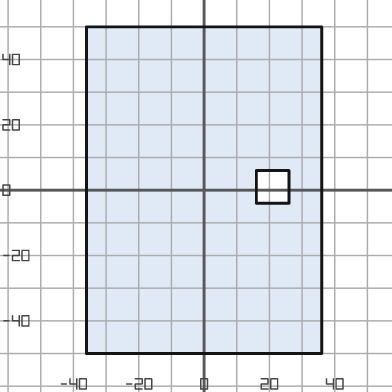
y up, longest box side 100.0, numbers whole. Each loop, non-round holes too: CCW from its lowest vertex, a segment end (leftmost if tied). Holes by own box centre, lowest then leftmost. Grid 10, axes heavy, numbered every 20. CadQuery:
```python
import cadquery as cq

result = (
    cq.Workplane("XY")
    .moveTo(-36.0, -50.0)
    .lineTo(36.0, -50.0)
    .lineTo(36.0, 50.0)
    .lineTo(-36.0, 50.0)
    .close()
    .moveTo(16.0, -4.0)
    .lineTo(26.0, -4.0)
    .lineTo(26.0, 6.0)
    .lineTo(16.0, 6.0)
    .close()
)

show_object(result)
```